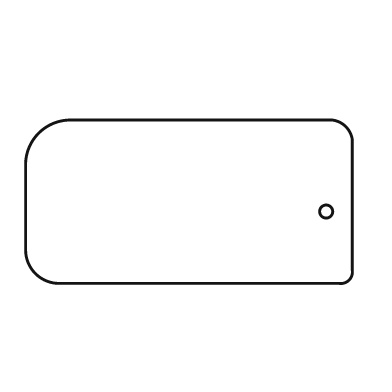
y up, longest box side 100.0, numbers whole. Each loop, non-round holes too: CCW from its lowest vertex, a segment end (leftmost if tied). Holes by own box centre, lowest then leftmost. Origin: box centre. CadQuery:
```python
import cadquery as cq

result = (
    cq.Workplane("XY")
    .moveTo(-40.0, -25.0)
    .lineTo(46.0, -25.0)
    .threePointArc((49.0, -24.0), (50.0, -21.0))
    .lineTo(50.0, 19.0)
    .threePointArc((48.0, 23.0), (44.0, 25.0))
    .lineTo(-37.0, 25.0)
    .threePointArc((-46.0, 21.0), (-50.0, 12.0))
    .lineTo(-50.0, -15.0)
    .threePointArc((-47.0, -22.0), (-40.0, -25.0))
    .close()
    .moveTo(42.0, -3.0)
    .circle(2.0)
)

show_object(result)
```